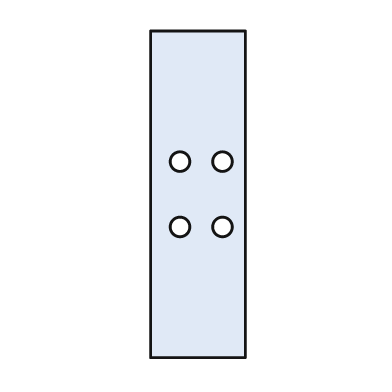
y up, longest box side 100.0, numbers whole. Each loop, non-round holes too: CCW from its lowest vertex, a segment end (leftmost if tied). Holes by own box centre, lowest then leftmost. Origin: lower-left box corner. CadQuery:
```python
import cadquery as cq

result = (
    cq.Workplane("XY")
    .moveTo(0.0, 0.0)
    .lineTo(29.0, 0.0)
    .lineTo(29.0, 100.0)
    .lineTo(0.0, 100.0)
    .close()
    .moveTo(9.0, 40.0)
    .circle(3.0)
    .moveTo(22.0, 40.0)
    .circle(3.0)
    .moveTo(9.0, 60.0)
    .circle(3.0)
    .moveTo(22.0, 60.0)
    .circle(3.0)
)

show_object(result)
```